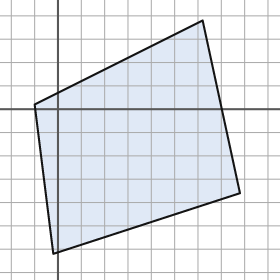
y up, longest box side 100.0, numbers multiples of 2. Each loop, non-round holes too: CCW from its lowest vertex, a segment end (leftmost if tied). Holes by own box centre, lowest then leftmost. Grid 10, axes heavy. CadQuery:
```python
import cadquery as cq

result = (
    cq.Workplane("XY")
    .moveTo(-2.0, -62.0)
    .lineTo(78.0, -36.0)
    .lineTo(62.0, 38.0)
    .lineTo(-10.0, 2.0)
    .close()
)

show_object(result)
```